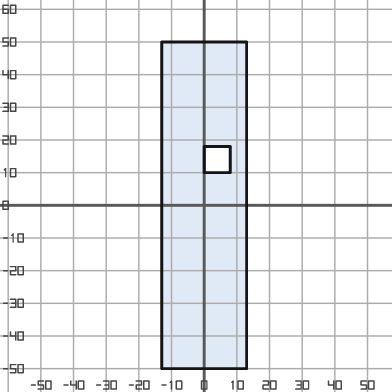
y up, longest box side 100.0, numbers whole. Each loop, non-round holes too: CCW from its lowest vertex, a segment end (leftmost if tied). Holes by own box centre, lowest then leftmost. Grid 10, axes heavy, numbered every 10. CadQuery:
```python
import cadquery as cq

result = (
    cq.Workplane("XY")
    .moveTo(-13.0, -50.0)
    .lineTo(13.0, -50.0)
    .lineTo(13.0, 50.0)
    .lineTo(-13.0, 50.0)
    .close()
    .moveTo(0.0, 10.0)
    .lineTo(8.0, 10.0)
    .lineTo(8.0, 18.0)
    .lineTo(0.0, 18.0)
    .close()
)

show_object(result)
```